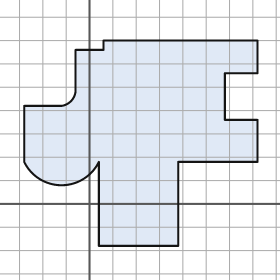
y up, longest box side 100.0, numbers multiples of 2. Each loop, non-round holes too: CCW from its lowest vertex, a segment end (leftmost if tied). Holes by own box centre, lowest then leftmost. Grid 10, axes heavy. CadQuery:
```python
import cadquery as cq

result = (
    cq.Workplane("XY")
    .moveTo(4.0, -18.0)
    .lineTo(38.0, -18.0)
    .lineTo(38.0, 18.0)
    .lineTo(72.0, 18.0)
    .lineTo(72.0, 36.0)
    .lineTo(58.0, 36.0)
    .lineTo(58.0, 56.0)
    .lineTo(72.0, 56.0)
    .lineTo(72.0, 70.0)
    .lineTo(6.0, 70.0)
    .lineTo(6.0, 66.0)
    .lineTo(-6.0, 66.0)
    .lineTo(-6.0, 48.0)
    .threePointArc((-8.0, 44.0), (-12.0, 42.0))
    .lineTo(-28.0, 42.0)
    .lineTo(-28.0, 18.0)
    .threePointArc((-12.0, 8.0), (4.0, 18.0))
    .close()
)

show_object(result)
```